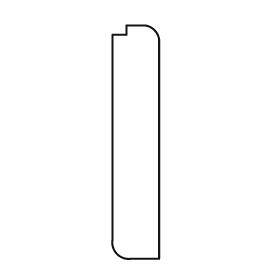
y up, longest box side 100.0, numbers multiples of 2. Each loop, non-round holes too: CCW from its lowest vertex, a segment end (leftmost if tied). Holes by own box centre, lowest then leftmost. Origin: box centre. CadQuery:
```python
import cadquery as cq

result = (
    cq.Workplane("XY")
    .moveTo(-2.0, -50.0)
    .lineTo(10.0, -50.0)
    .lineTo(10.0, 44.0)
    .threePointArc((8.0, 48.0), (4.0, 50.0))
    .lineTo(-4.0, 50.0)
    .lineTo(-4.0, 46.0)
    .lineTo(-10.0, 46.0)
    .lineTo(-10.0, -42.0)
    .threePointArc((-8.0, -48.0), (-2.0, -50.0))
    .close()
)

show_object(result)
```